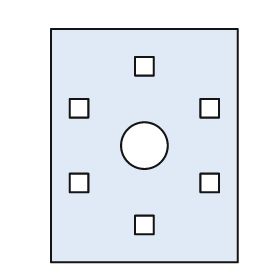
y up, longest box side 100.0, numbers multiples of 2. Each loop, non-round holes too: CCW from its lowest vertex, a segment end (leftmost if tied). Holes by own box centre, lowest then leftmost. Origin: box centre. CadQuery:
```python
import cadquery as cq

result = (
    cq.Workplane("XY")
    .moveTo(-40.0, -50.0)
    .lineTo(40.0, -50.0)
    .lineTo(40.0, 50.0)
    .lineTo(-40.0, 50.0)
    .close()
    .moveTo(-4.0, -38.0)
    .lineTo(4.0, -38.0)
    .lineTo(4.0, -30.0)
    .lineTo(-4.0, -30.0)
    .close()
    .moveTo(-32.0, -20.0)
    .lineTo(-24.0, -20.0)
    .lineTo(-24.0, -12.0)
    .lineTo(-32.0, -12.0)
    .close()
    .moveTo(24.0, -20.0)
    .lineTo(32.0, -20.0)
    .lineTo(32.0, -12.0)
    .lineTo(24.0, -12.0)
    .close()
    .moveTo(0.0, 0.0)
    .circle(10.0)
    .moveTo(-32.0, 12.0)
    .lineTo(-24.0, 12.0)
    .lineTo(-24.0, 20.0)
    .lineTo(-32.0, 20.0)
    .close()
    .moveTo(24.0, 12.0)
    .lineTo(32.0, 12.0)
    .lineTo(32.0, 20.0)
    .lineTo(24.0, 20.0)
    .close()
    .moveTo(-4.0, 30.0)
    .lineTo(4.0, 30.0)
    .lineTo(4.0, 38.0)
    .lineTo(-4.0, 38.0)
    .close()
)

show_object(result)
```